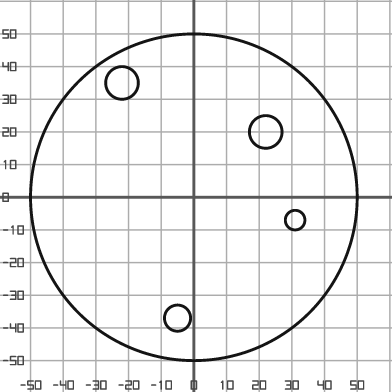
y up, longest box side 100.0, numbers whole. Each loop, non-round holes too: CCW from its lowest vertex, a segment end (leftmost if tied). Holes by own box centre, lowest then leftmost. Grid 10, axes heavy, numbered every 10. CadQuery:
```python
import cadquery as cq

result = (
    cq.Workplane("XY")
    .moveTo(0.0, 0.0)
    .circle(50.0)
    .moveTo(-5.0, -37.0)
    .circle(4.0)
    .moveTo(31.0, -7.0)
    .circle(3.0)
    .moveTo(22.0, 20.0)
    .circle(5.0)
    .moveTo(-22.0, 35.0)
    .circle(5.0)
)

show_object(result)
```